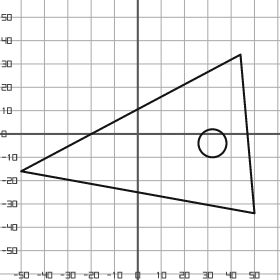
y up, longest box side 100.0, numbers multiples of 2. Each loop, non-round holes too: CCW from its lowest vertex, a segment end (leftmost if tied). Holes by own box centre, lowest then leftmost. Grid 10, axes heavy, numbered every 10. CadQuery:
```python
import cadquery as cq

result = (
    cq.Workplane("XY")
    .moveTo(50.0, -34.0)
    .lineTo(44.0, 34.0)
    .lineTo(-50.0, -16.0)
    .close()
    .moveTo(32.0, -4.0)
    .circle(6.0)
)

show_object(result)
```